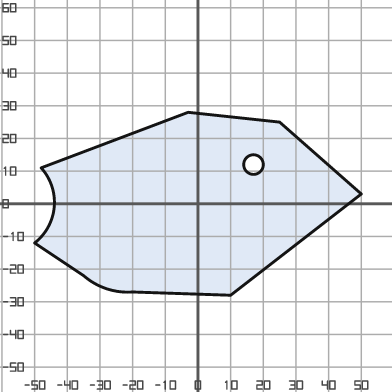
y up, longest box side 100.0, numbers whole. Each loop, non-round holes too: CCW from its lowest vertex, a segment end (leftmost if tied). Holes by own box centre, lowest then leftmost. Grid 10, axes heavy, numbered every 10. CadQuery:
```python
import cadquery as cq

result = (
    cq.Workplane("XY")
    .moveTo(10.0, -28.0)
    .lineTo(50.0, 3.0)
    .lineTo(25.0, 25.0)
    .lineTo(-3.0, 28.0)
    .lineTo(-48.0, 11.0)
    .threePointArc((-44.0, -1.0), (-50.0, -12.0))
    .lineTo(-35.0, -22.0)
    .threePointArc((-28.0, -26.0), (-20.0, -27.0))
    .close()
    .moveTo(17.0, 12.0)
    .circle(3.0)
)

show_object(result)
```